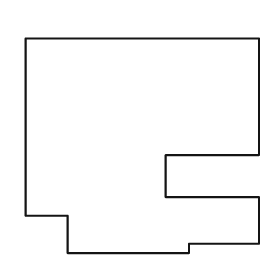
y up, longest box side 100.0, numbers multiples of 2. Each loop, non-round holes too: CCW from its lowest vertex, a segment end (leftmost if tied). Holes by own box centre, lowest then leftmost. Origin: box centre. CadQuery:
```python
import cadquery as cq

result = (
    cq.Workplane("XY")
    .moveTo(-32.0, -46.0)
    .lineTo(20.0, -46.0)
    .lineTo(20.0, -42.0)
    .lineTo(50.0, -42.0)
    .lineTo(50.0, -22.0)
    .lineTo(10.0, -22.0)
    .lineTo(10.0, -4.0)
    .lineTo(50.0, -4.0)
    .lineTo(50.0, 46.0)
    .lineTo(-50.0, 46.0)
    .lineTo(-50.0, -30.0)
    .lineTo(-32.0, -30.0)
    .close()
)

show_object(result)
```